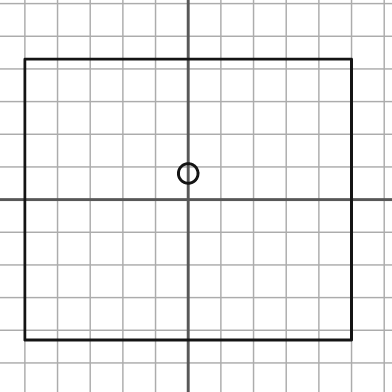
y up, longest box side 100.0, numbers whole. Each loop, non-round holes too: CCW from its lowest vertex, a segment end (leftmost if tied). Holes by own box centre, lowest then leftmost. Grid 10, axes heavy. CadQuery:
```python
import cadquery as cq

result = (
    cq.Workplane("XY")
    .moveTo(-50.0, -43.0)
    .lineTo(50.0, -43.0)
    .lineTo(50.0, 43.0)
    .lineTo(-50.0, 43.0)
    .close()
    .moveTo(0.0, 8.0)
    .circle(3.0)
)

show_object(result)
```